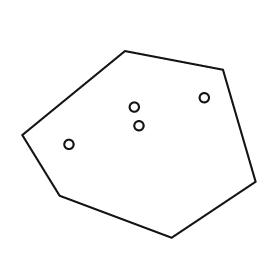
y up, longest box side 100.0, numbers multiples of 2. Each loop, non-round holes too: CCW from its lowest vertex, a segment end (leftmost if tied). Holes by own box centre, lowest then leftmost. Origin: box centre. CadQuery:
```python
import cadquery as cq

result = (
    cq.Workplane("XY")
    .moveTo(14.0, -40.0)
    .lineTo(50.0, -16.0)
    .lineTo(36.0, 32.0)
    .lineTo(-6.0, 40.0)
    .lineTo(-50.0, 4.0)
    .lineTo(-34.0, -22.0)
    .close()
    .moveTo(-30.0, 0.0)
    .circle(2.0)
    .moveTo(0.0, 8.0)
    .circle(2.0)
    .moveTo(-2.0, 16.0)
    .circle(2.0)
    .moveTo(28.0, 20.0)
    .circle(2.0)
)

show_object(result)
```